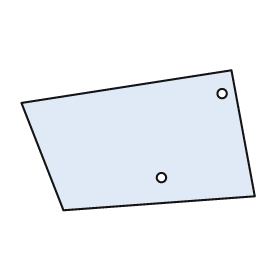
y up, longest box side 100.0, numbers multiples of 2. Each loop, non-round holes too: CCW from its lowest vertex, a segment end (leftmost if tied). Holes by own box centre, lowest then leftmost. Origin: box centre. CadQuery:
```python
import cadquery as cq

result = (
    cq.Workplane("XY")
    .moveTo(-32.0, -30.0)
    .lineTo(50.0, -24.0)
    .lineTo(40.0, 30.0)
    .lineTo(-50.0, 16.0)
    .close()
    .moveTo(10.0, -16.0)
    .circle(2.0)
    .moveTo(36.0, 20.0)
    .circle(2.0)
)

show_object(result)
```